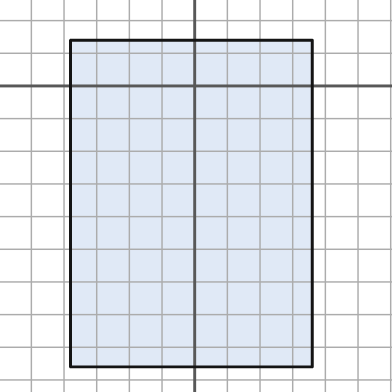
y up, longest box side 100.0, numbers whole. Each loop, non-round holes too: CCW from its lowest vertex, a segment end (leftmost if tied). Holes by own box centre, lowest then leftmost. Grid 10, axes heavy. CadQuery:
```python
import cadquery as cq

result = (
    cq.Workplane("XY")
    .moveTo(-38.0, -86.0)
    .lineTo(36.0, -86.0)
    .lineTo(36.0, 14.0)
    .lineTo(-38.0, 14.0)
    .close()
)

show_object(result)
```